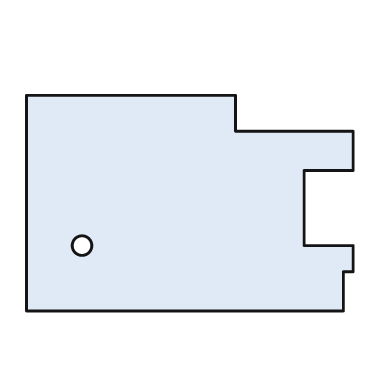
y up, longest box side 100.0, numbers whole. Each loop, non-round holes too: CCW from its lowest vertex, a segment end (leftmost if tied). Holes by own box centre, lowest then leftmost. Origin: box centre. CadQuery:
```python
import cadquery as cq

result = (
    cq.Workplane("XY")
    .moveTo(-50.0, -33.0)
    .lineTo(47.0, -33.0)
    .lineTo(47.0, -21.0)
    .lineTo(50.0, -21.0)
    .lineTo(50.0, -13.0)
    .lineTo(35.0, -13.0)
    .lineTo(35.0, 10.0)
    .lineTo(50.0, 10.0)
    .lineTo(50.0, 22.0)
    .lineTo(14.0, 22.0)
    .lineTo(14.0, 33.0)
    .lineTo(-50.0, 33.0)
    .close()
    .moveTo(-33.0, -13.0)
    .circle(3.0)
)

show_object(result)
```